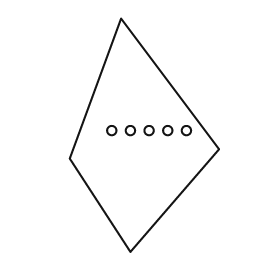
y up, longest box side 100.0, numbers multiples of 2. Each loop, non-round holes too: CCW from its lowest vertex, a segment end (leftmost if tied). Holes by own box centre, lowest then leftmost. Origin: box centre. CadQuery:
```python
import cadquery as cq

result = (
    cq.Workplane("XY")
    .moveTo(-6.0, -50.0)
    .lineTo(32.0, -6.0)
    .lineTo(-10.0, 50.0)
    .lineTo(-32.0, -10.0)
    .close()
    .moveTo(-14.0, 2.0)
    .circle(2.0)
    .moveTo(-6.0, 2.0)
    .circle(2.0)
    .moveTo(2.0, 2.0)
    .circle(2.0)
    .moveTo(10.0, 2.0)
    .circle(2.0)
    .moveTo(18.0, 2.0)
    .circle(2.0)
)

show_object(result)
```